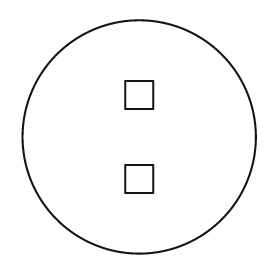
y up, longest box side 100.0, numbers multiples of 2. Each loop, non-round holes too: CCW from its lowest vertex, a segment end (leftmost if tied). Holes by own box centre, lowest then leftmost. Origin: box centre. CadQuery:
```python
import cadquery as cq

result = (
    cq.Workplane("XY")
    .moveTo(0.0, 0.0)
    .circle(50.0)
    .moveTo(-6.0, -24.0)
    .lineTo(6.0, -24.0)
    .lineTo(6.0, -12.0)
    .lineTo(-6.0, -12.0)
    .close()
    .moveTo(-6.0, 12.0)
    .lineTo(6.0, 12.0)
    .lineTo(6.0, 24.0)
    .lineTo(-6.0, 24.0)
    .close()
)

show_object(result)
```